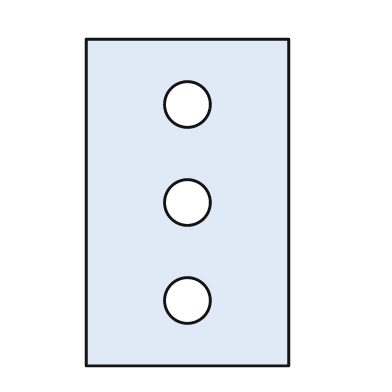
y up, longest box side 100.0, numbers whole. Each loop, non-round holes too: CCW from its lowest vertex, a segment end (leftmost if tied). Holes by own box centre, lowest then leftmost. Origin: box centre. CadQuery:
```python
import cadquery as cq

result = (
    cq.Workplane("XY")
    .moveTo(-31.0, -50.0)
    .lineTo(31.0, -50.0)
    .lineTo(31.0, 50.0)
    .lineTo(-31.0, 50.0)
    .close()
    .moveTo(0.0, -30.0)
    .circle(7.0)
    .moveTo(0.0, 0.0)
    .circle(7.0)
    .moveTo(0.0, 30.0)
    .circle(7.0)
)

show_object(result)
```